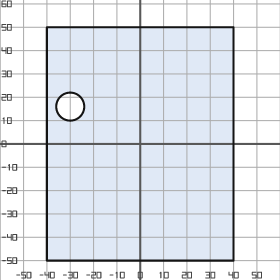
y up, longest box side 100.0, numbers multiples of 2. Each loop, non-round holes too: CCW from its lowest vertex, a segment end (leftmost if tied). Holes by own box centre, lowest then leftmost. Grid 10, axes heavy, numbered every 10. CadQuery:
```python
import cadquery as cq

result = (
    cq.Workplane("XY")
    .moveTo(-40.0, -50.0)
    .lineTo(40.0, -50.0)
    .lineTo(40.0, 50.0)
    .lineTo(-40.0, 50.0)
    .close()
    .moveTo(-30.0, 16.0)
    .circle(6.0)
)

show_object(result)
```